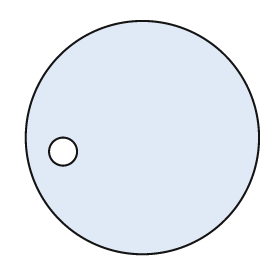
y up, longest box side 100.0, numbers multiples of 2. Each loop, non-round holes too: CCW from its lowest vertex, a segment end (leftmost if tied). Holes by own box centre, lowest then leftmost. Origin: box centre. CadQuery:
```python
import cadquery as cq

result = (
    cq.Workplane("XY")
    .moveTo(0.0, 0.0)
    .circle(50.0)
    .moveTo(-34.0, -6.0)
    .circle(6.0)
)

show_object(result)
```